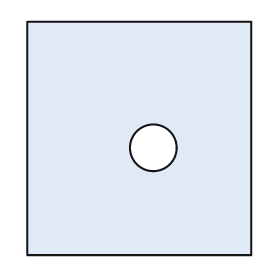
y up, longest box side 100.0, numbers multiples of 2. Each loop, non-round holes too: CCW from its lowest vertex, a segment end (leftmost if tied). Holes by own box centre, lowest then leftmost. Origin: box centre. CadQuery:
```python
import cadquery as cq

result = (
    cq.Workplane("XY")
    .moveTo(-48.0, -50.0)
    .lineTo(48.0, -50.0)
    .lineTo(48.0, 50.0)
    .lineTo(-48.0, 50.0)
    .close()
    .moveTo(6.0, -4.0)
    .circle(10.0)
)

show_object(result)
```